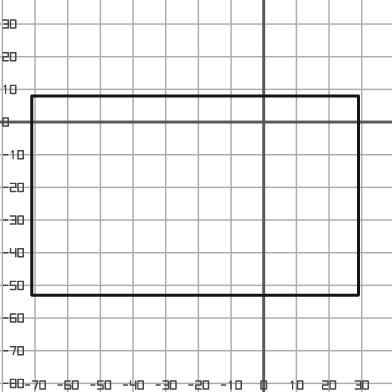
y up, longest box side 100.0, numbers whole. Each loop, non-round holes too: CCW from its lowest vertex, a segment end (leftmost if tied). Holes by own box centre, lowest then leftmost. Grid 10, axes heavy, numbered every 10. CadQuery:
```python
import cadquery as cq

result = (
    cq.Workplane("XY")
    .moveTo(-71.0, -53.0)
    .lineTo(29.0, -53.0)
    .lineTo(29.0, 8.0)
    .lineTo(-71.0, 8.0)
    .close()
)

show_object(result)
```